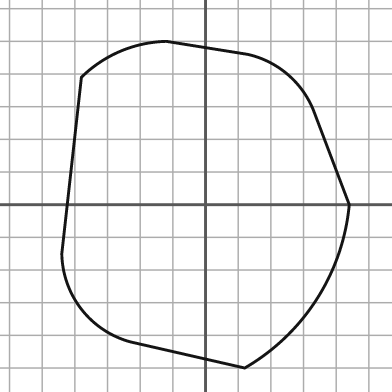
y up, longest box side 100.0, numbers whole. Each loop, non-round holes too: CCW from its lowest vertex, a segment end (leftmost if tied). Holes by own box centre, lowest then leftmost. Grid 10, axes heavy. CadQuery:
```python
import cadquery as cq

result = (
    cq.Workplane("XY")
    .moveTo(12.0, -50.0)
    .threePointArc((34.0, -29.0), (44.0, 0.0))
    .lineTo(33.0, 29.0)
    .threePointArc((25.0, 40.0), (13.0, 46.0))
    .lineTo(-12.0, 50.0)
    .threePointArc((-26.0, 47.0), (-38.0, 39.0))
    .lineTo(-44.0, -15.0)
    .threePointArc((-38.0, -32.0), (-23.0, -42.0))
    .close()
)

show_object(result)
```